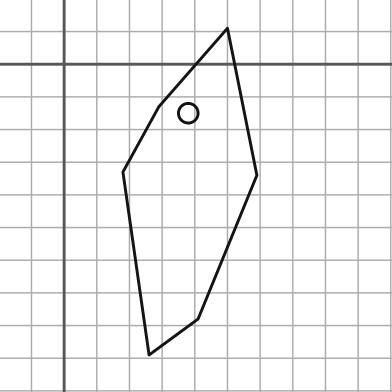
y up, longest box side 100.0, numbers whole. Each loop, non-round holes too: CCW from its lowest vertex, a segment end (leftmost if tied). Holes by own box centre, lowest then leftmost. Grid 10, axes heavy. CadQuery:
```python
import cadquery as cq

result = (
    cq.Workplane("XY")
    .moveTo(26.0, -89.0)
    .lineTo(41.0, -78.0)
    .lineTo(59.0, -34.0)
    .lineTo(50.0, 11.0)
    .lineTo(29.0, -13.0)
    .lineTo(18.0, -33.0)
    .close()
    .moveTo(38.0, -15.0)
    .circle(3.0)
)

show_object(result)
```